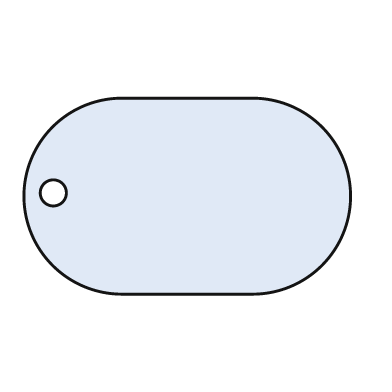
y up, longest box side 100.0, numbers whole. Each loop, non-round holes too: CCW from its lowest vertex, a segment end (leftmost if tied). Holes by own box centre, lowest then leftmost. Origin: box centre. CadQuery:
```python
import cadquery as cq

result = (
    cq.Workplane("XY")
    .moveTo(-20.0, -30.0)
    .lineTo(20.0, -30.0)
    .threePointArc((50.0, 0.0), (20.0, 30.0))
    .lineTo(-20.0, 30.0)
    .threePointArc((-50.0, 0.0), (-20.0, -30.0))
    .close()
    .moveTo(-41.0, 1.0)
    .circle(4.0)
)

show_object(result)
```